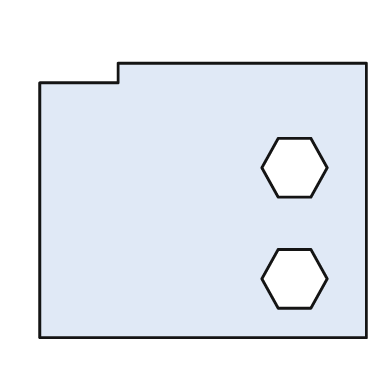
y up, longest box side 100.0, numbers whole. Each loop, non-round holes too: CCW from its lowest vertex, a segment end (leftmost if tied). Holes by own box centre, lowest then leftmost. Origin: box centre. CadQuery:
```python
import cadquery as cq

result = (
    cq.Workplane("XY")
    .moveTo(-50.0, -42.0)
    .lineTo(50.0, -42.0)
    .lineTo(50.0, 42.0)
    .lineTo(-26.0, 42.0)
    .lineTo(-26.0, 36.0)
    .lineTo(-50.0, 36.0)
    .close()
    .moveTo(23.0, -33.0)
    .lineTo(33.0, -33.0)
    .lineTo(38.0, -24.0)
    .lineTo(33.0, -15.0)
    .lineTo(23.0, -15.0)
    .lineTo(18.0, -24.0)
    .close()
    .moveTo(23.0, 1.0)
    .lineTo(33.0, 1.0)
    .lineTo(38.0, 10.0)
    .lineTo(33.0, 19.0)
    .lineTo(23.0, 19.0)
    .lineTo(18.0, 10.0)
    .close()
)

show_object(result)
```